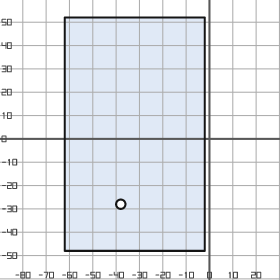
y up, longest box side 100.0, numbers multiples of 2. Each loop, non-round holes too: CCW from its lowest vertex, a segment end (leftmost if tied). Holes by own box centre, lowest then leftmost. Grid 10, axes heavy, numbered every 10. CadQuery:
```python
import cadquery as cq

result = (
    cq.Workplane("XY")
    .moveTo(-62.0, -48.0)
    .lineTo(-2.0, -48.0)
    .lineTo(-2.0, 52.0)
    .lineTo(-62.0, 52.0)
    .close()
    .moveTo(-38.0, -28.0)
    .circle(2.0)
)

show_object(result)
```